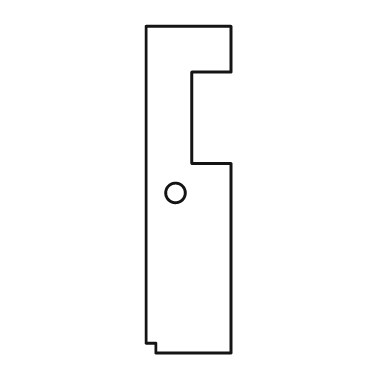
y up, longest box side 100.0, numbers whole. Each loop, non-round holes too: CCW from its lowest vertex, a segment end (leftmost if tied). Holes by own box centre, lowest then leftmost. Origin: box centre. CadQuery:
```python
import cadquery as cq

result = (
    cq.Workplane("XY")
    .moveTo(-10.0, -50.0)
    .lineTo(13.0, -50.0)
    .lineTo(13.0, 8.0)
    .lineTo(1.0, 8.0)
    .lineTo(1.0, 36.0)
    .lineTo(13.0, 36.0)
    .lineTo(13.0, 50.0)
    .lineTo(-13.0, 50.0)
    .lineTo(-13.0, -47.0)
    .lineTo(-10.0, -47.0)
    .close()
    .moveTo(-4.0, -1.0)
    .circle(3.0)
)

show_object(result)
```